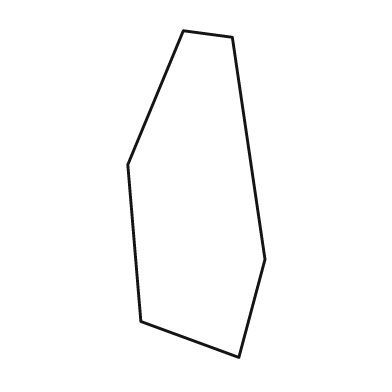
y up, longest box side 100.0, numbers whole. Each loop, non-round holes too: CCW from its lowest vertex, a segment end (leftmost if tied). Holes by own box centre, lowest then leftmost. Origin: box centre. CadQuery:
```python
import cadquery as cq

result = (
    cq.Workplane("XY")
    .moveTo(13.0, -50.0)
    .lineTo(21.0, -20.0)
    .lineTo(11.0, 48.0)
    .lineTo(-4.0, 50.0)
    .lineTo(-21.0, 9.0)
    .lineTo(-17.0, -39.0)
    .close()
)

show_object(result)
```